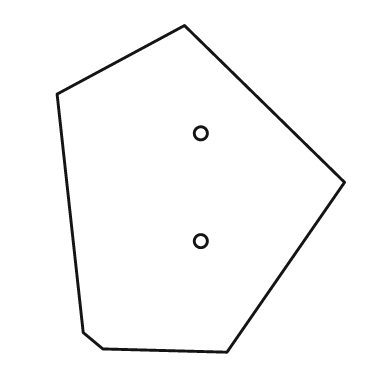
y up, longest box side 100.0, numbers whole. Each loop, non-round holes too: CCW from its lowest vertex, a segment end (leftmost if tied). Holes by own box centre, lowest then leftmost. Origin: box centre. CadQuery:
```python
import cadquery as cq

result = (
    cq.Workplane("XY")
    .moveTo(8.0, -50.0)
    .lineTo(44.0, 2.0)
    .lineTo(-5.0, 50.0)
    .lineTo(-44.0, 29.0)
    .lineTo(-36.0, -44.0)
    .lineTo(-30.0, -49.0)
    .close()
    .moveTo(0.0, -16.0)
    .circle(2.0)
    .moveTo(0.0, 17.0)
    .circle(2.0)
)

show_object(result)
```